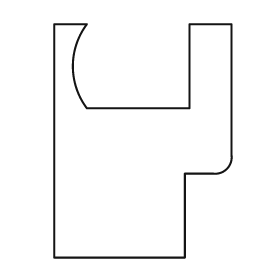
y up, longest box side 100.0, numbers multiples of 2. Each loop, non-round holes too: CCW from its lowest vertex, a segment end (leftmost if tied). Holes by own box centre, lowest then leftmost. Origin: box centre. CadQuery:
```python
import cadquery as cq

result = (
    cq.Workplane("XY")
    .moveTo(-38.0, -50.0)
    .lineTo(18.0, -50.0)
    .lineTo(18.0, -14.0)
    .lineTo(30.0, -14.0)
    .threePointArc((36.0, -12.0), (38.0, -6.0))
    .lineTo(38.0, 50.0)
    .lineTo(20.0, 50.0)
    .lineTo(20.0, 14.0)
    .lineTo(-24.0, 14.0)
    .threePointArc((-30.0, 32.0), (-24.0, 50.0))
    .lineTo(-38.0, 50.0)
    .close()
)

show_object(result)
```